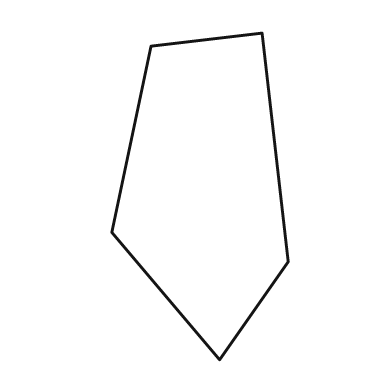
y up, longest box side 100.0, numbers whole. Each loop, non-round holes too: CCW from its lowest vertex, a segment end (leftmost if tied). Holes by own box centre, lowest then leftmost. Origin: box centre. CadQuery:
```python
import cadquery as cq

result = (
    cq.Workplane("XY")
    .moveTo(6.0, -50.0)
    .lineTo(27.0, -20.0)
    .lineTo(19.0, 50.0)
    .lineTo(-15.0, 46.0)
    .lineTo(-27.0, -11.0)
    .close()
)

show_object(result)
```